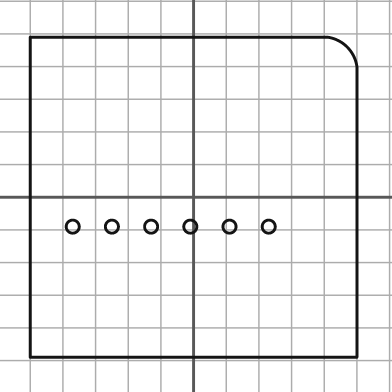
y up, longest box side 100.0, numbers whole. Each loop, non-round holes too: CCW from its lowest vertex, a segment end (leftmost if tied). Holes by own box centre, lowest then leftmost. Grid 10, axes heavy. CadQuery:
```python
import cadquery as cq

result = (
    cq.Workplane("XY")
    .moveTo(-50.0, -49.0)
    .lineTo(50.0, -49.0)
    .lineTo(50.0, 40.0)
    .threePointArc((47.0, 46.0), (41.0, 49.0))
    .lineTo(-50.0, 49.0)
    .close()
    .moveTo(-37.0, -9.0)
    .circle(2.0)
    .moveTo(-25.0, -9.0)
    .circle(2.0)
    .moveTo(-13.0, -9.0)
    .circle(2.0)
    .moveTo(-1.0, -9.0)
    .circle(2.0)
    .moveTo(11.0, -9.0)
    .circle(2.0)
    .moveTo(23.0, -9.0)
    .circle(2.0)
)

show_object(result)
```